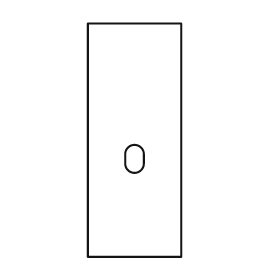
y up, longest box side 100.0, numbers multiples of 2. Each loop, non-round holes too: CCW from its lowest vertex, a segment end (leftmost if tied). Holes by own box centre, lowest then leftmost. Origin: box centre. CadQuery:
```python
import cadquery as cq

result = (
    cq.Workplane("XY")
    .moveTo(-20.0, -50.0)
    .lineTo(20.0, -50.0)
    .lineTo(20.0, 50.0)
    .lineTo(-20.0, 50.0)
    .close()
    .moveTo(-4.0, -10.0)
    .threePointArc((0.0, -14.0), (4.0, -10.0))
    .lineTo(4.0, -6.0)
    .threePointArc((0.0, -2.0), (-4.0, -6.0))
    .close()
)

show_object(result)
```